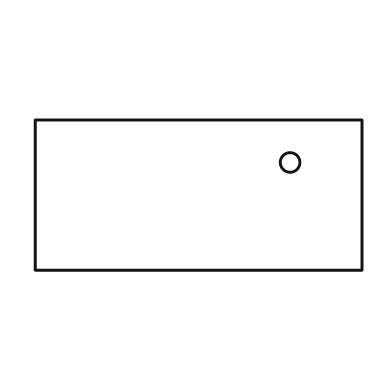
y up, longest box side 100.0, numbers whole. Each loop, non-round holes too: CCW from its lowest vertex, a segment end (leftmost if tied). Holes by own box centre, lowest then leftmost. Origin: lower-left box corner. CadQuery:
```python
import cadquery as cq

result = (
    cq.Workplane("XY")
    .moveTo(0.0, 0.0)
    .lineTo(100.0, 0.0)
    .lineTo(100.0, 46.0)
    .lineTo(0.0, 46.0)
    .close()
    .moveTo(78.0, 33.0)
    .circle(3.0)
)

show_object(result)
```